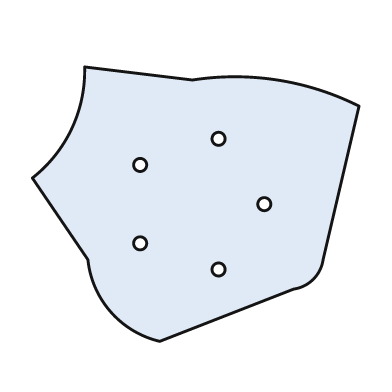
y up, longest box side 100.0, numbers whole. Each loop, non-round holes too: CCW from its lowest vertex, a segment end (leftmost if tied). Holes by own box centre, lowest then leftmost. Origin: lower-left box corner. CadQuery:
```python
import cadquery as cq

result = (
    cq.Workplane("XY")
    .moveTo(39.0, 0.0)
    .lineTo(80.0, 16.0)
    .threePointArc((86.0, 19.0), (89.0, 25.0))
    .lineTo(100.0, 72.0)
    .threePointArc((75.0, 80.0), (49.0, 80.0))
    .lineTo(16.0, 84.0)
    .threePointArc((12.0, 65.0), (0.0, 50.0))
    .lineTo(17.0, 25.0)
    .threePointArc((24.0, 9.0), (39.0, 0.0))
    .close()
    .moveTo(57.0, 22.0)
    .circle(2.0)
    .moveTo(33.0, 30.0)
    .circle(2.0)
    .moveTo(71.0, 42.0)
    .circle(2.0)
    .moveTo(33.0, 54.0)
    .circle(2.0)
    .moveTo(57.0, 62.0)
    .circle(2.0)
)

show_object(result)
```